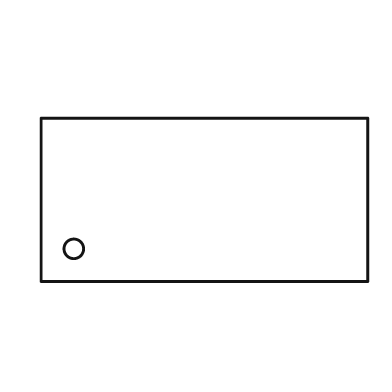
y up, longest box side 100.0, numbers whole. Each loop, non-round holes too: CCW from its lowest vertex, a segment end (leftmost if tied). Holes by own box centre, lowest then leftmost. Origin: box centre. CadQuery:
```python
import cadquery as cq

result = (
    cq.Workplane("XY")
    .moveTo(-50.0, -25.0)
    .lineTo(50.0, -25.0)
    .lineTo(50.0, 25.0)
    .lineTo(-50.0, 25.0)
    .close()
    .moveTo(-40.0, -15.0)
    .circle(3.0)
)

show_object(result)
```